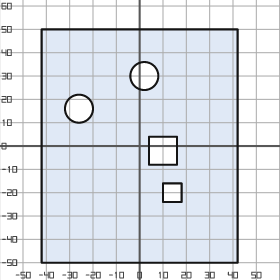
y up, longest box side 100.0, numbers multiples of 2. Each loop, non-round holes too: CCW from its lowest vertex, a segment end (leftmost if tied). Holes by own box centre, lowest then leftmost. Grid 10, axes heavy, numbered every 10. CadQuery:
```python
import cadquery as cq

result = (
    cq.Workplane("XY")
    .moveTo(-42.0, -50.0)
    .lineTo(42.0, -50.0)
    .lineTo(42.0, 50.0)
    .lineTo(-42.0, 50.0)
    .close()
    .moveTo(10.0, -24.0)
    .lineTo(18.0, -24.0)
    .lineTo(18.0, -16.0)
    .lineTo(10.0, -16.0)
    .close()
    .moveTo(4.0, -8.0)
    .lineTo(16.0, -8.0)
    .lineTo(16.0, 4.0)
    .lineTo(4.0, 4.0)
    .close()
    .moveTo(-26.0, 16.0)
    .circle(6.0)
    .moveTo(2.0, 30.0)
    .circle(6.0)
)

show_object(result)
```